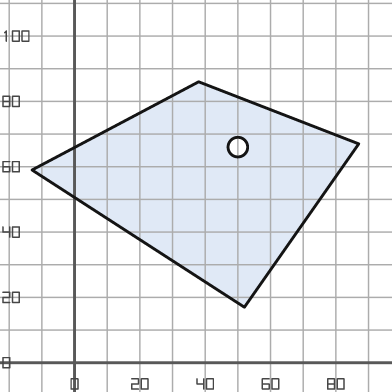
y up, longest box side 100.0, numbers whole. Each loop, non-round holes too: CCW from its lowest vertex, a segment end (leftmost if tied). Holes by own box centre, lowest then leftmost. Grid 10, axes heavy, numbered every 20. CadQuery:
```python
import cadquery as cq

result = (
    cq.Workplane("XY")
    .moveTo(52.0, 17.0)
    .lineTo(87.0, 67.0)
    .lineTo(38.0, 86.0)
    .lineTo(-13.0, 59.0)
    .close()
    .moveTo(50.0, 66.0)
    .circle(3.0)
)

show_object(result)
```